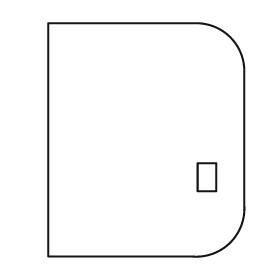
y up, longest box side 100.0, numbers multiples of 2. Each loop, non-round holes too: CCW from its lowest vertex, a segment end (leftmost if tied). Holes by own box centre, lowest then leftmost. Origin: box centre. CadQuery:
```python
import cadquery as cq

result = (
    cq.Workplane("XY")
    .moveTo(-42.0, -50.0)
    .lineTo(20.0, -50.0)
    .threePointArc((36.0, -44.0), (42.0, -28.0))
    .lineTo(42.0, 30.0)
    .threePointArc((36.0, 44.0), (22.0, 50.0))
    .lineTo(-42.0, 50.0)
    .close()
    .moveTo(22.0, -22.0)
    .lineTo(30.0, -22.0)
    .lineTo(30.0, -10.0)
    .lineTo(22.0, -10.0)
    .close()
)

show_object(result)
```